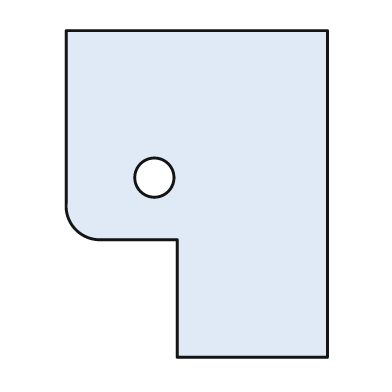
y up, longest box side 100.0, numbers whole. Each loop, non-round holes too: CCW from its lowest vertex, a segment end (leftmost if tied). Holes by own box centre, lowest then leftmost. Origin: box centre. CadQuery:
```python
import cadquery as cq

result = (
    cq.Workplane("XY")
    .moveTo(-6.0, -50.0)
    .lineTo(40.0, -50.0)
    .lineTo(40.0, 50.0)
    .lineTo(-40.0, 50.0)
    .lineTo(-40.0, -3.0)
    .threePointArc((-37.0, -11.0), (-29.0, -14.0))
    .lineTo(-6.0, -14.0)
    .close()
    .moveTo(-13.0, 5.0)
    .circle(6.0)
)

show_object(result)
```